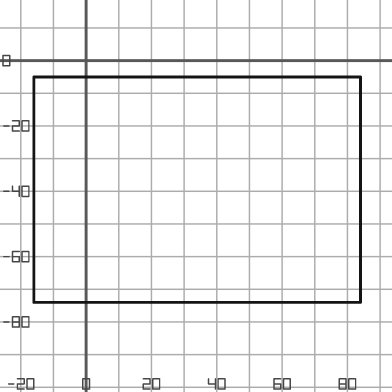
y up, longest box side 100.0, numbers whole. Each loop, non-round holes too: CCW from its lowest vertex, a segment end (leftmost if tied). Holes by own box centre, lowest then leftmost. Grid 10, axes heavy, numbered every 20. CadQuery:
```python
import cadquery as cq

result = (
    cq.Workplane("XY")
    .moveTo(-16.0, -74.0)
    .lineTo(84.0, -74.0)
    .lineTo(84.0, -5.0)
    .lineTo(-16.0, -5.0)
    .close()
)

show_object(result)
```